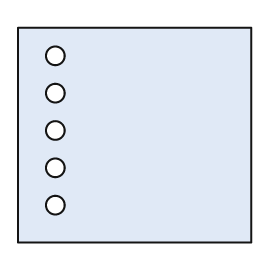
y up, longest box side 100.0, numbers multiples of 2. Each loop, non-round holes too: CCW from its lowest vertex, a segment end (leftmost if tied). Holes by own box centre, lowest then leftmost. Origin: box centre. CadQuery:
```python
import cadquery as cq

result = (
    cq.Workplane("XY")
    .moveTo(-50.0, -46.0)
    .lineTo(50.0, -46.0)
    .lineTo(50.0, 46.0)
    .lineTo(-50.0, 46.0)
    .close()
    .moveTo(-34.0, -30.0)
    .circle(4.0)
    .moveTo(-34.0, -14.0)
    .circle(4.0)
    .moveTo(-34.0, 2.0)
    .circle(4.0)
    .moveTo(-34.0, 18.0)
    .circle(4.0)
    .moveTo(-34.0, 34.0)
    .circle(4.0)
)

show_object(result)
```